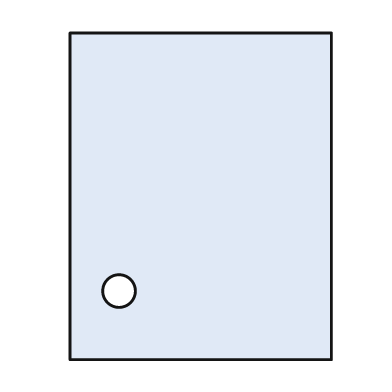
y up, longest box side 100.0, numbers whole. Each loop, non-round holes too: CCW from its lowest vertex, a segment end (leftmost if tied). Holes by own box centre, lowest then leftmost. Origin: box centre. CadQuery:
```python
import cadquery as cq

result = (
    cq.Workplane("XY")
    .moveTo(-40.0, -50.0)
    .lineTo(40.0, -50.0)
    .lineTo(40.0, 50.0)
    .lineTo(-40.0, 50.0)
    .close()
    .moveTo(-25.0, -29.0)
    .circle(5.0)
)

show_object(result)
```